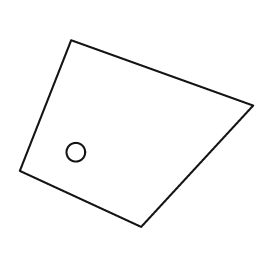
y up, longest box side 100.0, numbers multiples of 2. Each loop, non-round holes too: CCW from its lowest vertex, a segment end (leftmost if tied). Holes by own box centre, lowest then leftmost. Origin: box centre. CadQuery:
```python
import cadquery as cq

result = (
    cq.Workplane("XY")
    .moveTo(2.0, -40.0)
    .lineTo(50.0, 12.0)
    .lineTo(-28.0, 40.0)
    .lineTo(-50.0, -16.0)
    .close()
    .moveTo(-26.0, -8.0)
    .circle(4.0)
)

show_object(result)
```